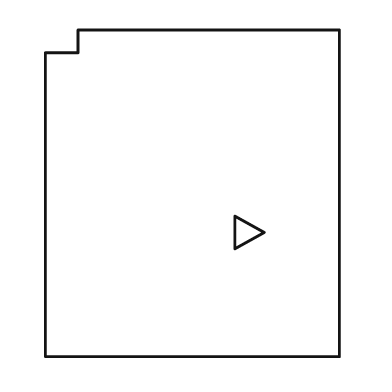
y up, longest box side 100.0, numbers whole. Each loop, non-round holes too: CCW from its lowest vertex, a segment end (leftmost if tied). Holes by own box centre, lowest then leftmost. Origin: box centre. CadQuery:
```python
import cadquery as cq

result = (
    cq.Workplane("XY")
    .moveTo(-45.0, -50.0)
    .lineTo(45.0, -50.0)
    .lineTo(45.0, 50.0)
    .lineTo(-35.0, 50.0)
    .lineTo(-35.0, 43.0)
    .lineTo(-45.0, 43.0)
    .close()
    .moveTo(13.0, -17.0)
    .lineTo(22.0, -12.0)
    .lineTo(13.0, -7.0)
    .close()
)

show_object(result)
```